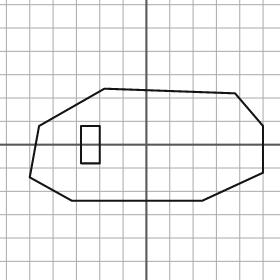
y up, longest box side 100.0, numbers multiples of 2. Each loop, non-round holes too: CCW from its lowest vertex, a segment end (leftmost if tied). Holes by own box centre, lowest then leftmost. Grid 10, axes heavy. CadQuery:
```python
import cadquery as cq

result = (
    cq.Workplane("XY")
    .moveTo(-32.0, -24.0)
    .lineTo(24.0, -24.0)
    .lineTo(50.0, -12.0)
    .lineTo(50.0, 8.0)
    .lineTo(38.0, 22.0)
    .lineTo(-18.0, 24.0)
    .lineTo(-46.0, 8.0)
    .lineTo(-50.0, -14.0)
    .close()
    .moveTo(-28.0, -8.0)
    .lineTo(-20.0, -8.0)
    .lineTo(-20.0, 8.0)
    .lineTo(-28.0, 8.0)
    .close()
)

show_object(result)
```